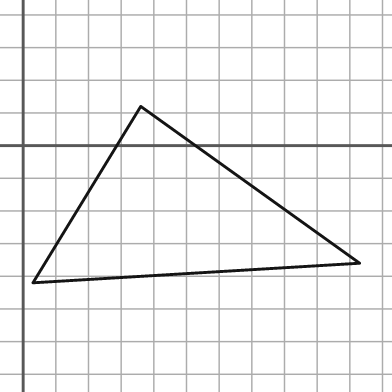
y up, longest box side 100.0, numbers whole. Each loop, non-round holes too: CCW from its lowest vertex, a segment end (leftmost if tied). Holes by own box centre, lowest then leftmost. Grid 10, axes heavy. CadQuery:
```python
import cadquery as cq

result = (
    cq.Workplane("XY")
    .moveTo(3.0, -42.0)
    .lineTo(103.0, -36.0)
    .lineTo(36.0, 12.0)
    .close()
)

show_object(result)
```